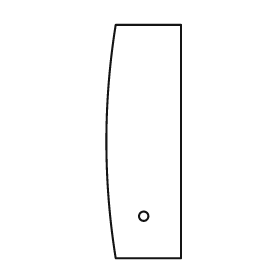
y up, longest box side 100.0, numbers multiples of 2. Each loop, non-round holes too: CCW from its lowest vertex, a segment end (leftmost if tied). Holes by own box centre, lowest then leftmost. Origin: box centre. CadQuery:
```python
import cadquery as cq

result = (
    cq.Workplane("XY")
    .moveTo(-12.0, -50.0)
    .lineTo(16.0, -50.0)
    .lineTo(16.0, 50.0)
    .lineTo(-12.0, 50.0)
    .threePointArc((-16.0, 0.0), (-12.0, -50.0))
    .close()
    .moveTo(0.0, -32.0)
    .circle(2.0)
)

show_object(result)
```